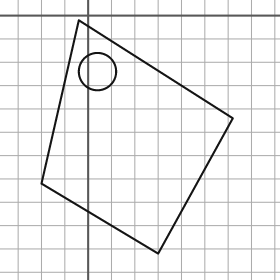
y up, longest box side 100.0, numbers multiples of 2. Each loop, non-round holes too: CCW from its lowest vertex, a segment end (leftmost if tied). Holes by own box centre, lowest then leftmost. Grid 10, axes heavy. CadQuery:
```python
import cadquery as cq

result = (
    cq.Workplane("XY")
    .moveTo(30.0, -102.0)
    .lineTo(62.0, -44.0)
    .lineTo(-4.0, -2.0)
    .lineTo(-20.0, -72.0)
    .close()
    .moveTo(4.0, -24.0)
    .circle(8.0)
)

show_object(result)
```